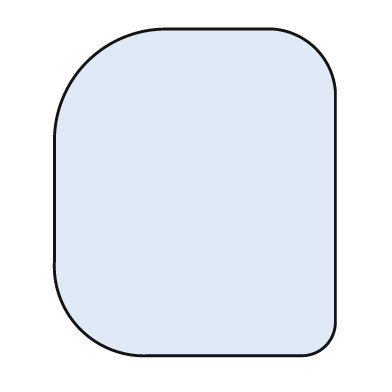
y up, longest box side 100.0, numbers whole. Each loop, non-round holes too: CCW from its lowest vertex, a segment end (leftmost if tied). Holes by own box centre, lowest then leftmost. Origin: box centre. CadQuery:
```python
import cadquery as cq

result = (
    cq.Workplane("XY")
    .moveTo(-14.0, -50.0)
    .lineTo(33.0, -50.0)
    .threePointArc((40.0, -47.0), (43.0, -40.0))
    .lineTo(43.0, 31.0)
    .threePointArc((37.0, 44.0), (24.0, 50.0))
    .lineTo(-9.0, 50.0)
    .threePointArc((-33.0, 40.0), (-43.0, 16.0))
    .lineTo(-43.0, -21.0)
    .threePointArc((-35.0, -42.0), (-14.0, -50.0))
    .close()
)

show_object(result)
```